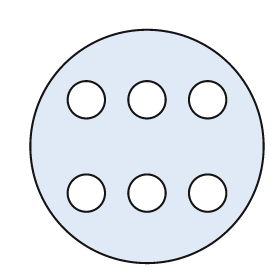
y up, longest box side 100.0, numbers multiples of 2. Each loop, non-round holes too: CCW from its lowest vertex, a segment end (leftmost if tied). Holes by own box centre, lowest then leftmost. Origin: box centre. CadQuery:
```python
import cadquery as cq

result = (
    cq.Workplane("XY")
    .moveTo(0.0, 0.0)
    .circle(50.0)
    .moveTo(-26.0, -20.0)
    .circle(8.0)
    .moveTo(0.0, -20.0)
    .circle(8.0)
    .moveTo(26.0, -20.0)
    .circle(8.0)
    .moveTo(-26.0, 20.0)
    .circle(8.0)
    .moveTo(0.0, 20.0)
    .circle(8.0)
    .moveTo(26.0, 20.0)
    .circle(8.0)
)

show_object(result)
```